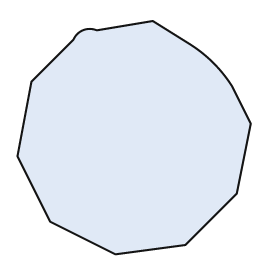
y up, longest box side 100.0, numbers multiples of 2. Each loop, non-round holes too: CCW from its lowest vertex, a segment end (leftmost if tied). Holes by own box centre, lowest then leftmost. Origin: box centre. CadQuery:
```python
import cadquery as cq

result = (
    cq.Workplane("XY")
    .moveTo(-8.0, -50.0)
    .lineTo(22.0, -46.0)
    .lineTo(44.0, -24.0)
    .lineTo(50.0, 6.0)
    .lineTo(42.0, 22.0)
    .threePointArc((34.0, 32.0), (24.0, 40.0))
    .lineTo(8.0, 50.0)
    .lineTo(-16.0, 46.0)
    .threePointArc((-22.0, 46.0), (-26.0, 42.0))
    .lineTo(-44.0, 24.0)
    .lineTo(-50.0, -8.0)
    .lineTo(-36.0, -36.0)
    .close()
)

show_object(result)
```